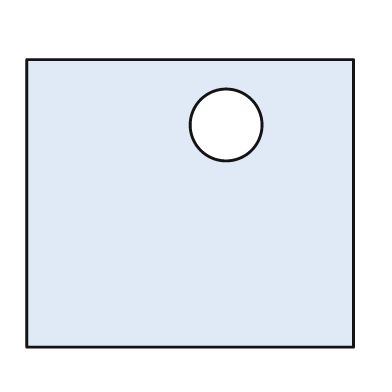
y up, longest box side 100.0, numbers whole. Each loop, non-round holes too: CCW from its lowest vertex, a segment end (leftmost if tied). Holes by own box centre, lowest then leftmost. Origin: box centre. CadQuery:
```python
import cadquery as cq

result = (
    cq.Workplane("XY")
    .moveTo(-50.0, -44.0)
    .lineTo(50.0, -44.0)
    .lineTo(50.0, 44.0)
    .lineTo(-50.0, 44.0)
    .close()
    .moveTo(11.0, 24.0)
    .circle(11.0)
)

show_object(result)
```